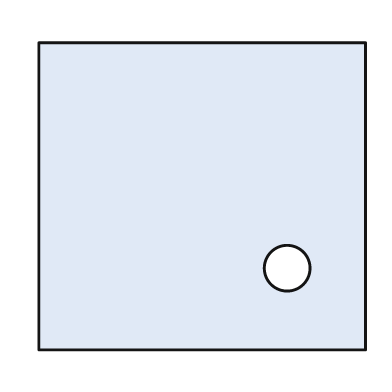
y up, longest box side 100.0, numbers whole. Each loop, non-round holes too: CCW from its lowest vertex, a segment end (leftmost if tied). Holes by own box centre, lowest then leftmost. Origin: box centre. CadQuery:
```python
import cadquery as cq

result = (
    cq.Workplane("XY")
    .moveTo(-50.0, -47.0)
    .lineTo(50.0, -47.0)
    .lineTo(50.0, 47.0)
    .lineTo(-50.0, 47.0)
    .close()
    .moveTo(26.0, -22.0)
    .circle(7.0)
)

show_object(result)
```